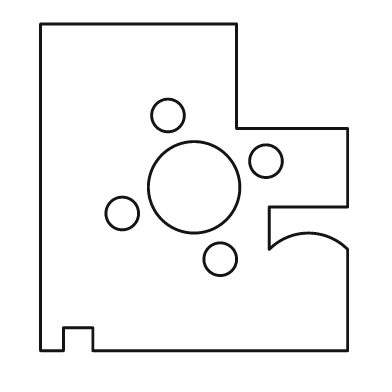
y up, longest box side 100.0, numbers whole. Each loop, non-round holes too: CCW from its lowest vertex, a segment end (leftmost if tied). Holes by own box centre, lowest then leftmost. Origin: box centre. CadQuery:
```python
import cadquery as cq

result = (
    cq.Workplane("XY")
    .moveTo(-47.0, -50.0)
    .lineTo(-40.0, -50.0)
    .lineTo(-40.0, -43.0)
    .lineTo(-31.0, -43.0)
    .lineTo(-31.0, -50.0)
    .lineTo(47.0, -50.0)
    .lineTo(47.0, -19.0)
    .threePointArc((35.0, -14.0), (23.0, -19.0))
    .lineTo(23.0, -6.0)
    .lineTo(47.0, -6.0)
    .lineTo(47.0, 18.0)
    .lineTo(13.0, 18.0)
    .lineTo(13.0, 50.0)
    .lineTo(-47.0, 50.0)
    .close()
    .moveTo(8.0, -22.0)
    .circle(5.0)
    .moveTo(-22.0, -8.0)
    .circle(5.0)
    .moveTo(0.0, 0.0)
    .circle(14.0)
    .moveTo(22.0, 8.0)
    .circle(5.0)
    .moveTo(-8.0, 22.0)
    .circle(5.0)
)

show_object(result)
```